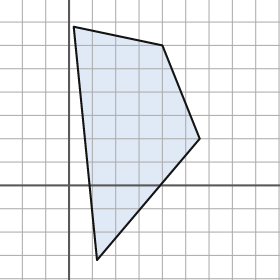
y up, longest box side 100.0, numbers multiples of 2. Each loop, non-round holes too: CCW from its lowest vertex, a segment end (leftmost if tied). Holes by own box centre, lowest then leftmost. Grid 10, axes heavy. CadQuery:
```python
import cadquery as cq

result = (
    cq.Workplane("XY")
    .moveTo(12.0, -32.0)
    .lineTo(56.0, 20.0)
    .lineTo(40.0, 60.0)
    .lineTo(2.0, 68.0)
    .close()
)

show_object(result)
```